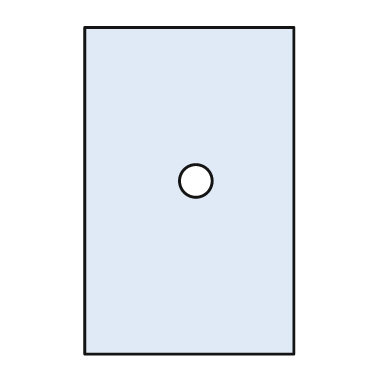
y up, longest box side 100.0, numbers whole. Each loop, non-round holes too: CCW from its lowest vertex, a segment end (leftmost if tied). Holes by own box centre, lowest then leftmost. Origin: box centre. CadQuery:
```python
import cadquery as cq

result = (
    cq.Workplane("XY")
    .moveTo(-32.0, -50.0)
    .lineTo(32.0, -50.0)
    .lineTo(32.0, 50.0)
    .lineTo(-32.0, 50.0)
    .close()
    .moveTo(2.0, 3.0)
    .circle(5.0)
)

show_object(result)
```